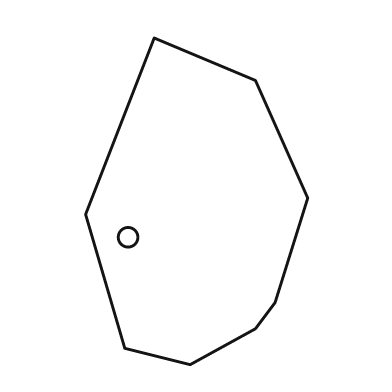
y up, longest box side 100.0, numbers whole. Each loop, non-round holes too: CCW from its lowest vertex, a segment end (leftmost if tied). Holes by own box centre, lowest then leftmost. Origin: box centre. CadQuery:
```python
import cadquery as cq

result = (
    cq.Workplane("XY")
    .moveTo(-2.0, -50.0)
    .lineTo(18.0, -39.0)
    .lineTo(24.0, -31.0)
    .lineTo(34.0, 1.0)
    .lineTo(18.0, 37.0)
    .lineTo(-13.0, 50.0)
    .lineTo(-34.0, -4.0)
    .lineTo(-22.0, -45.0)
    .close()
    .moveTo(-21.0, -11.0)
    .circle(3.0)
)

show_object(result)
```